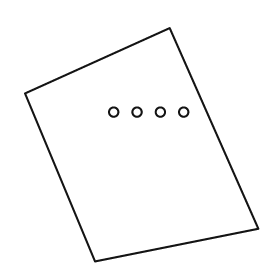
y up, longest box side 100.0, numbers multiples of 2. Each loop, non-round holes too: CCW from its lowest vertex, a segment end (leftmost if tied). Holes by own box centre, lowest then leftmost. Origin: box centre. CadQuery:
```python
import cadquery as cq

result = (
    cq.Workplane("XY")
    .moveTo(-20.0, -50.0)
    .lineTo(50.0, -36.0)
    .lineTo(12.0, 50.0)
    .lineTo(-50.0, 22.0)
    .close()
    .moveTo(-12.0, 14.0)
    .circle(2.0)
    .moveTo(-2.0, 14.0)
    .circle(2.0)
    .moveTo(8.0, 14.0)
    .circle(2.0)
    .moveTo(18.0, 14.0)
    .circle(2.0)
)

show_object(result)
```